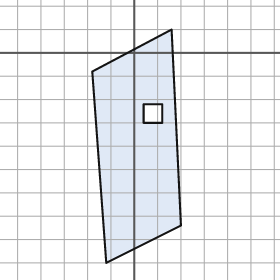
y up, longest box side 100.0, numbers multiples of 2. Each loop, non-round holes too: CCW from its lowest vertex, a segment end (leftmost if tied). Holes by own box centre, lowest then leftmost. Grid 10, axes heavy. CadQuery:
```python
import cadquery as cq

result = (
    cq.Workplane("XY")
    .moveTo(-12.0, -90.0)
    .lineTo(20.0, -74.0)
    .lineTo(16.0, 10.0)
    .lineTo(-18.0, -8.0)
    .close()
    .moveTo(4.0, -30.0)
    .lineTo(12.0, -30.0)
    .lineTo(12.0, -22.0)
    .lineTo(4.0, -22.0)
    .close()
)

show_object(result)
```